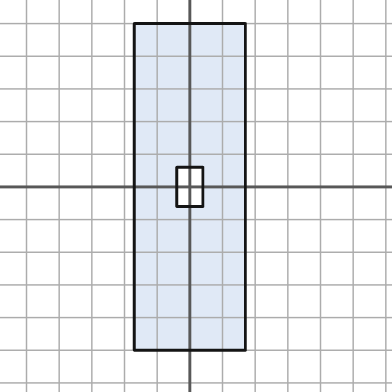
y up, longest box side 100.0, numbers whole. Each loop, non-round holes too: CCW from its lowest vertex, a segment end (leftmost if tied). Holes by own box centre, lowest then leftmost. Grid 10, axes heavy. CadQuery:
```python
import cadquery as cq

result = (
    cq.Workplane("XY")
    .moveTo(-17.0, -50.0)
    .lineTo(17.0, -50.0)
    .lineTo(17.0, 50.0)
    .lineTo(-17.0, 50.0)
    .close()
    .moveTo(-4.0, -6.0)
    .lineTo(4.0, -6.0)
    .lineTo(4.0, 6.0)
    .lineTo(-4.0, 6.0)
    .close()
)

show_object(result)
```